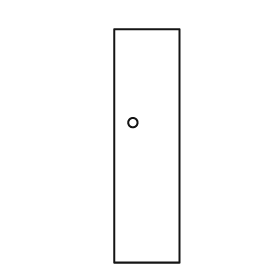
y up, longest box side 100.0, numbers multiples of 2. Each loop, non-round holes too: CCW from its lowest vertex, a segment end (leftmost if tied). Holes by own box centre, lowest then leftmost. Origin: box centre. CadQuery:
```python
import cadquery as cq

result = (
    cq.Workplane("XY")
    .moveTo(-14.0, -50.0)
    .lineTo(14.0, -50.0)
    .lineTo(14.0, 50.0)
    .lineTo(-14.0, 50.0)
    .close()
    .moveTo(-6.0, 10.0)
    .circle(2.0)
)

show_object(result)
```